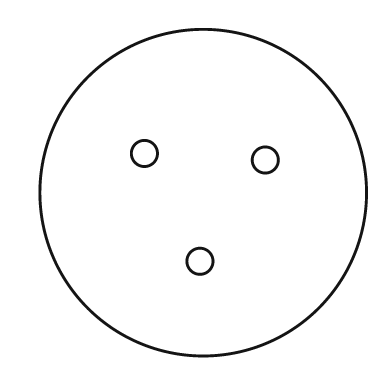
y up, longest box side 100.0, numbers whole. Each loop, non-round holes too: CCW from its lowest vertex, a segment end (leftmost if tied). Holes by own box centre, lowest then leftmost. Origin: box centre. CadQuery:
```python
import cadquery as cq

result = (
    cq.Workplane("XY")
    .moveTo(0.0, 0.0)
    .circle(50.0)
    .moveTo(-1.0, -21.0)
    .circle(4.0)
    .moveTo(19.0, 10.0)
    .circle(4.0)
    .moveTo(-18.0, 12.0)
    .circle(4.0)
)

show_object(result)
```